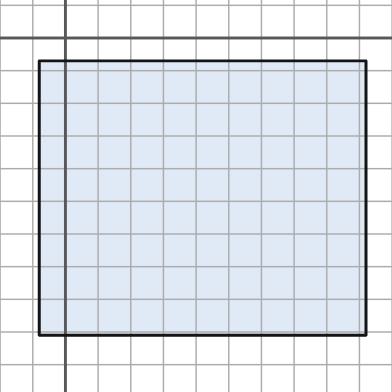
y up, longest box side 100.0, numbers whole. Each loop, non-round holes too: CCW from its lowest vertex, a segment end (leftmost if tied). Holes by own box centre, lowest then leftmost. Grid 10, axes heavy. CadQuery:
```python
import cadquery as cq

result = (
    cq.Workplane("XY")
    .moveTo(-8.0, -91.0)
    .lineTo(92.0, -91.0)
    .lineTo(92.0, -7.0)
    .lineTo(-8.0, -7.0)
    .close()
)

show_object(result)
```